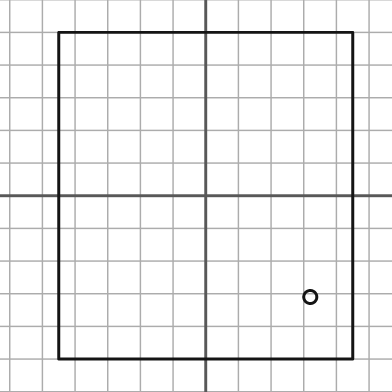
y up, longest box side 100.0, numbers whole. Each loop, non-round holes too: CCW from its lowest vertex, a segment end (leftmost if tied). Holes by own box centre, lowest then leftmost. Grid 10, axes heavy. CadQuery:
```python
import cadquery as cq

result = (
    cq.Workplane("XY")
    .moveTo(-45.0, -50.0)
    .lineTo(45.0, -50.0)
    .lineTo(45.0, 50.0)
    .lineTo(-45.0, 50.0)
    .close()
    .moveTo(32.0, -31.0)
    .circle(2.0)
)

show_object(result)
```